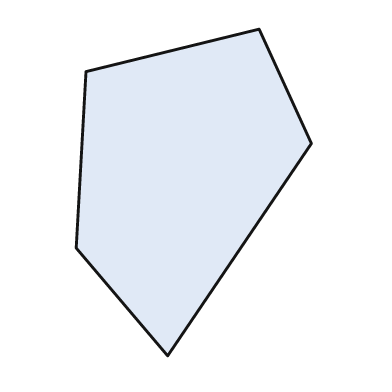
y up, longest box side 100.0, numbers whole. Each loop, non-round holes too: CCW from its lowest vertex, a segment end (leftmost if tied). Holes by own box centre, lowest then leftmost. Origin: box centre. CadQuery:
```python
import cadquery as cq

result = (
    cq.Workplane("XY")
    .moveTo(-8.0, -50.0)
    .lineTo(36.0, 15.0)
    .lineTo(20.0, 50.0)
    .lineTo(-33.0, 37.0)
    .lineTo(-36.0, -17.0)
    .close()
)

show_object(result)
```